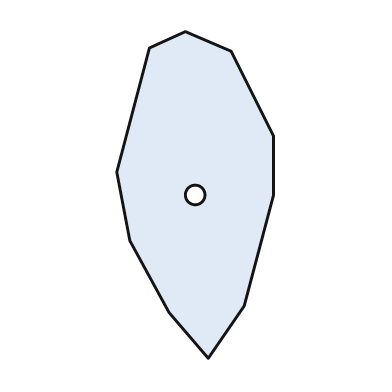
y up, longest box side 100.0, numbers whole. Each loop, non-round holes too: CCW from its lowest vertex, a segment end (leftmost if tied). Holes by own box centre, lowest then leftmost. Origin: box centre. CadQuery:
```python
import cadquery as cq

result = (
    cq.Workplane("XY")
    .moveTo(4.0, -50.0)
    .lineTo(15.0, -34.0)
    .lineTo(24.0, 0.0)
    .lineTo(24.0, 18.0)
    .lineTo(11.0, 44.0)
    .lineTo(-3.0, 50.0)
    .lineTo(-14.0, 45.0)
    .lineTo(-24.0, 7.0)
    .lineTo(-20.0, -14.0)
    .lineTo(-8.0, -36.0)
    .close()
    .moveTo(0.0, 0.0)
    .circle(3.0)
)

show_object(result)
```